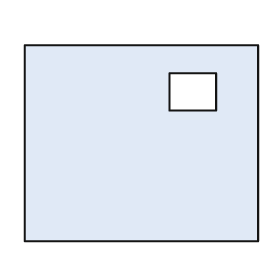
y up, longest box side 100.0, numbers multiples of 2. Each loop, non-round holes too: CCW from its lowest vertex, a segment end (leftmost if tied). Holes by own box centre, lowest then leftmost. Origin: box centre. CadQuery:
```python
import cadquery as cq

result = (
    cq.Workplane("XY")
    .moveTo(-50.0, -42.0)
    .lineTo(50.0, -42.0)
    .lineTo(50.0, 42.0)
    .lineTo(-50.0, 42.0)
    .close()
    .moveTo(12.0, 14.0)
    .lineTo(32.0, 14.0)
    .lineTo(32.0, 30.0)
    .lineTo(12.0, 30.0)
    .close()
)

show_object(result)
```